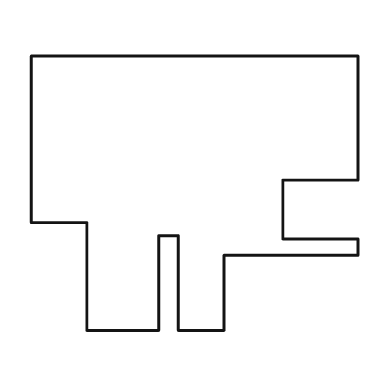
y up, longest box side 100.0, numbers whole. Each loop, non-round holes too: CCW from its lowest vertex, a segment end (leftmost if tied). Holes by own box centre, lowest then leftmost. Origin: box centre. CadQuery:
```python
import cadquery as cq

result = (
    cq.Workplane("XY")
    .moveTo(-33.0, -42.0)
    .lineTo(-11.0, -42.0)
    .lineTo(-11.0, -13.0)
    .lineTo(-5.0, -13.0)
    .lineTo(-5.0, -42.0)
    .lineTo(9.0, -42.0)
    .lineTo(9.0, -19.0)
    .lineTo(50.0, -19.0)
    .lineTo(50.0, -14.0)
    .lineTo(27.0, -14.0)
    .lineTo(27.0, 4.0)
    .lineTo(50.0, 4.0)
    .lineTo(50.0, 42.0)
    .lineTo(-50.0, 42.0)
    .lineTo(-50.0, -9.0)
    .lineTo(-33.0, -9.0)
    .close()
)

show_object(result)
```